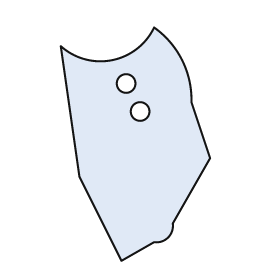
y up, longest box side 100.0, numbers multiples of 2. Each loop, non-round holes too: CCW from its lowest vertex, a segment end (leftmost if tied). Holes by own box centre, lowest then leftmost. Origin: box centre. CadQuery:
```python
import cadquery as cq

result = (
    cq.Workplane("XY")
    .moveTo(-6.0, -50.0)
    .lineTo(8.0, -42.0)
    .threePointArc((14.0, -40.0), (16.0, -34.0))
    .lineTo(32.0, -6.0)
    .lineTo(24.0, 18.0)
    .threePointArc((20.0, 36.0), (8.0, 50.0))
    .threePointArc((-10.0, 36.0), (-32.0, 42.0))
    .lineTo(-24.0, -14.0)
    .close()
    .moveTo(2.0, 14.0)
    .circle(4.0)
    .moveTo(-4.0, 26.0)
    .circle(4.0)
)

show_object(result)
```